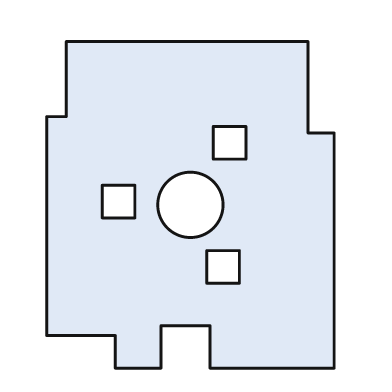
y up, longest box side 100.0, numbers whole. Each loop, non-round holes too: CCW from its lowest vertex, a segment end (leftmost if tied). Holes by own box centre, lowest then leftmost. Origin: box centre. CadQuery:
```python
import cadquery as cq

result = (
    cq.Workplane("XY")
    .moveTo(-23.0, -50.0)
    .lineTo(-9.0, -50.0)
    .lineTo(-9.0, -37.0)
    .lineTo(6.0, -37.0)
    .lineTo(6.0, -50.0)
    .lineTo(44.0, -50.0)
    .lineTo(44.0, 22.0)
    .lineTo(36.0, 22.0)
    .lineTo(36.0, 50.0)
    .lineTo(-38.0, 50.0)
    .lineTo(-38.0, 27.0)
    .lineTo(-44.0, 27.0)
    .lineTo(-44.0, -40.0)
    .lineTo(-23.0, -40.0)
    .close()
    .moveTo(5.0, -24.0)
    .lineTo(15.0, -24.0)
    .lineTo(15.0, -14.0)
    .lineTo(5.0, -14.0)
    .close()
    .moveTo(0.0, 0.0)
    .circle(10.0)
    .moveTo(-27.0, -4.0)
    .lineTo(-17.0, -4.0)
    .lineTo(-17.0, 6.0)
    .lineTo(-27.0, 6.0)
    .close()
    .moveTo(7.0, 14.0)
    .lineTo(17.0, 14.0)
    .lineTo(17.0, 24.0)
    .lineTo(7.0, 24.0)
    .close()
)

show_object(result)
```